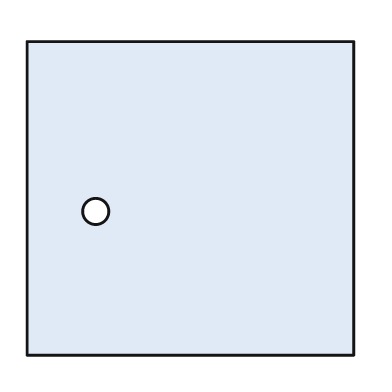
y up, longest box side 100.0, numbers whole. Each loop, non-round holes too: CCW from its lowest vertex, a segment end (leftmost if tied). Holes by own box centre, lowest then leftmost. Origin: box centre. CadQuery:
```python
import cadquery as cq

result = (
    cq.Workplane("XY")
    .moveTo(-50.0, -48.0)
    .lineTo(50.0, -48.0)
    .lineTo(50.0, 48.0)
    .lineTo(-50.0, 48.0)
    .close()
    .moveTo(-29.0, -4.0)
    .circle(4.0)
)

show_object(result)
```